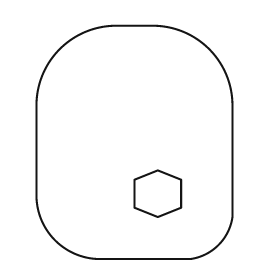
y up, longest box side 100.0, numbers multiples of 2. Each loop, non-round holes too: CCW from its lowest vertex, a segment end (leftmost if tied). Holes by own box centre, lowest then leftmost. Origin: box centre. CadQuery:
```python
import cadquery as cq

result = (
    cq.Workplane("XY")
    .moveTo(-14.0, -50.0)
    .lineTo(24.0, -50.0)
    .threePointArc((36.0, -44.0), (42.0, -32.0))
    .lineTo(42.0, 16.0)
    .threePointArc((32.0, 40.0), (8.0, 50.0))
    .lineTo(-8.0, 50.0)
    .threePointArc((-32.0, 40.0), (-42.0, 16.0))
    .lineTo(-42.0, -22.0)
    .threePointArc((-34.0, -42.0), (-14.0, -50.0))
    .close()
    .moveTo(10.0, -32.0)
    .lineTo(20.0, -28.0)
    .lineTo(20.0, -16.0)
    .lineTo(10.0, -12.0)
    .lineTo(0.0, -16.0)
    .lineTo(0.0, -28.0)
    .close()
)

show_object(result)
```